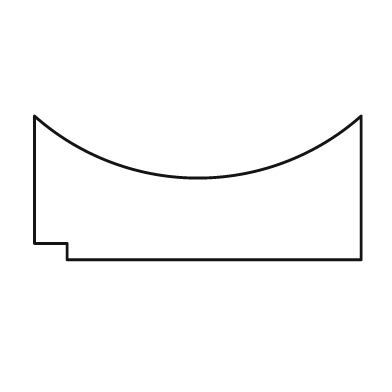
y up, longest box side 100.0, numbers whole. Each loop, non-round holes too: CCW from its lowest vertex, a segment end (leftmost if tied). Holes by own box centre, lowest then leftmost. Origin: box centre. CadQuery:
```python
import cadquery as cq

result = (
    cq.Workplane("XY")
    .moveTo(-40.0, -22.0)
    .lineTo(50.0, -22.0)
    .lineTo(50.0, 22.0)
    .threePointArc((0.0, 3.0), (-50.0, 22.0))
    .lineTo(-50.0, -17.0)
    .lineTo(-40.0, -17.0)
    .close()
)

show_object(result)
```